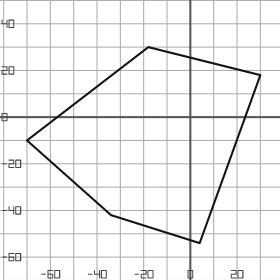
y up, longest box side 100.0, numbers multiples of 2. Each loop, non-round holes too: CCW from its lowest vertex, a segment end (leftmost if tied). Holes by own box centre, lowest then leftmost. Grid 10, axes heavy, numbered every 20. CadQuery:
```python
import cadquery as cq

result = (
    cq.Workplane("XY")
    .moveTo(4.0, -54.0)
    .lineTo(30.0, 18.0)
    .lineTo(-18.0, 30.0)
    .lineTo(-70.0, -10.0)
    .lineTo(-34.0, -42.0)
    .close()
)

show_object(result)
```